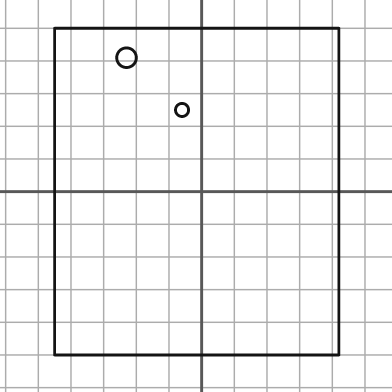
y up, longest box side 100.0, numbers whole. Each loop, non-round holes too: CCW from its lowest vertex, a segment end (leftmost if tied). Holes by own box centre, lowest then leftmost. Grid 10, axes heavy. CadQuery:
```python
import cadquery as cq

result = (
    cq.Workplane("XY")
    .moveTo(-45.0, -50.0)
    .lineTo(42.0, -50.0)
    .lineTo(42.0, 50.0)
    .lineTo(-45.0, 50.0)
    .close()
    .moveTo(-6.0, 25.0)
    .circle(2.0)
    .moveTo(-23.0, 41.0)
    .circle(3.0)
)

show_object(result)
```